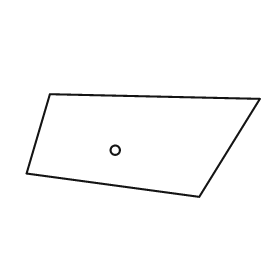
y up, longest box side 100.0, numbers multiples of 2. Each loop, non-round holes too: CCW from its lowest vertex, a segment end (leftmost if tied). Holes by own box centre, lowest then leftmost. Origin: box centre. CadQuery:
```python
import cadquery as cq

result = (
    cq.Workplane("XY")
    .moveTo(24.0, -22.0)
    .lineTo(50.0, 20.0)
    .lineTo(-40.0, 22.0)
    .lineTo(-50.0, -12.0)
    .close()
    .moveTo(-12.0, -2.0)
    .circle(2.0)
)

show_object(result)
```